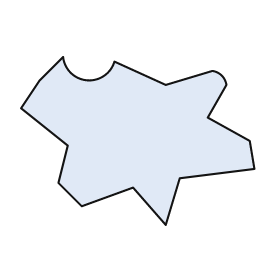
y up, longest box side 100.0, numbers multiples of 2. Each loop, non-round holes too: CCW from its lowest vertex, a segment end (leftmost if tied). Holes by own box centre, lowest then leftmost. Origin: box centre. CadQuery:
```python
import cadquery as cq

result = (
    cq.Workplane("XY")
    .moveTo(12.0, -36.0)
    .lineTo(18.0, -16.0)
    .lineTo(50.0, -12.0)
    .lineTo(48.0, 0.0)
    .lineTo(30.0, 10.0)
    .lineTo(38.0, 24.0)
    .threePointArc((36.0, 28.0), (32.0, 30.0))
    .lineTo(12.0, 24.0)
    .lineTo(-10.0, 34.0)
    .threePointArc((-22.0, 26.0), (-32.0, 36.0))
    .lineTo(-42.0, 26.0)
    .lineTo(-50.0, 14.0)
    .lineTo(-30.0, -2.0)
    .lineTo(-34.0, -18.0)
    .lineTo(-24.0, -28.0)
    .lineTo(-2.0, -20.0)
    .close()
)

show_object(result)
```